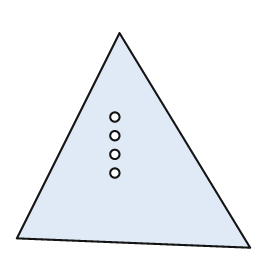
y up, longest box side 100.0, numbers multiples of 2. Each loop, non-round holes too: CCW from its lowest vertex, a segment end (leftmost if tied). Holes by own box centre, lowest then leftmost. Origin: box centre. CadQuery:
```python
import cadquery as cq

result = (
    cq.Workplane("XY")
    .moveTo(50.0, -46.0)
    .lineTo(-6.0, 46.0)
    .lineTo(-50.0, -42.0)
    .close()
    .moveTo(-8.0, -14.0)
    .circle(2.0)
    .moveTo(-8.0, -6.0)
    .circle(2.0)
    .moveTo(-8.0, 2.0)
    .circle(2.0)
    .moveTo(-8.0, 10.0)
    .circle(2.0)
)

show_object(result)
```